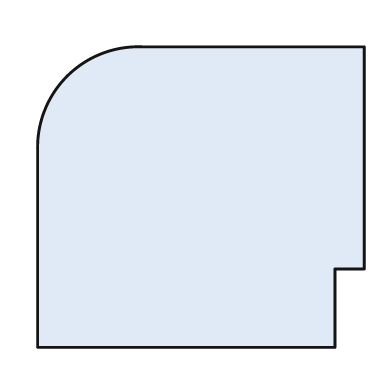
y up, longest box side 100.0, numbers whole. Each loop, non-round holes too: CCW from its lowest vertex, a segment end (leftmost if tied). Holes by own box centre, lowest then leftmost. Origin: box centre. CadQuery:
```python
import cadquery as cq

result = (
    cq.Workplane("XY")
    .moveTo(-50.0, -46.0)
    .lineTo(41.0, -46.0)
    .lineTo(41.0, -22.0)
    .lineTo(50.0, -22.0)
    .lineTo(50.0, 46.0)
    .lineTo(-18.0, 46.0)
    .threePointArc((-41.0, 37.0), (-50.0, 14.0))
    .close()
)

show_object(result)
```